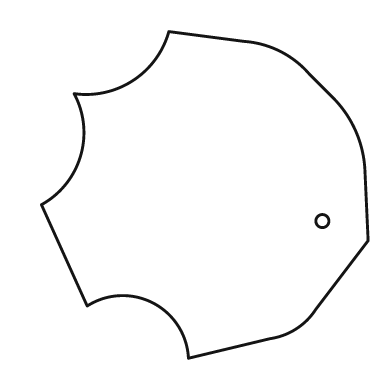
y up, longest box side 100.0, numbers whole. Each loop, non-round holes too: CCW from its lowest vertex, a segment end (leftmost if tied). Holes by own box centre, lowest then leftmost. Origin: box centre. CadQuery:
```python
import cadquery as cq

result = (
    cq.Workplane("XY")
    .moveTo(-5.0, -50.0)
    .lineTo(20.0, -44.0)
    .threePointArc((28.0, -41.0), (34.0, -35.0))
    .lineTo(50.0, -14.0)
    .lineTo(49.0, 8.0)
    .threePointArc((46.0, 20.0), (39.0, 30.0))
    .lineTo(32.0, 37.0)
    .threePointArc((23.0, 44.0), (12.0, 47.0))
    .lineTo(-11.0, 50.0)
    .threePointArc((-22.0, 35.0), (-40.0, 31.0))
    .threePointArc((-38.0, 12.0), (-50.0, -3.0))
    .lineTo(-36.0, -34.0)
    .threePointArc((-16.0, -33.0), (-5.0, -50.0))
    .close()
    .moveTo(36.0, -8.0)
    .circle(2.0)
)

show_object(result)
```